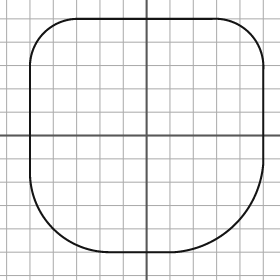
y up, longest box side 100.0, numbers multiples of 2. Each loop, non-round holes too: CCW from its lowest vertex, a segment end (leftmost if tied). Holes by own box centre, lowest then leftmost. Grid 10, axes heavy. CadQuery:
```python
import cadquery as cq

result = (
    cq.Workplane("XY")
    .moveTo(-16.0, -50.0)
    .lineTo(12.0, -50.0)
    .threePointArc((38.0, -38.0), (50.0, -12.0))
    .lineTo(50.0, 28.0)
    .threePointArc((44.0, 44.0), (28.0, 50.0))
    .lineTo(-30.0, 50.0)
    .threePointArc((-44.0, 44.0), (-50.0, 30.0))
    .lineTo(-50.0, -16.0)
    .threePointArc((-40.0, -40.0), (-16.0, -50.0))
    .close()
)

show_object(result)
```